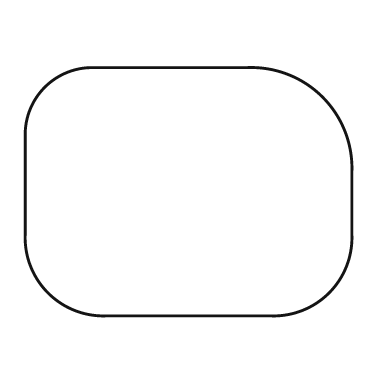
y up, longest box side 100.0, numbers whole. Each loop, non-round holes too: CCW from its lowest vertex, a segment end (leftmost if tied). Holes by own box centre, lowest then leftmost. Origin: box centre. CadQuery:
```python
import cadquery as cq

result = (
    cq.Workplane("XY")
    .moveTo(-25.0, -38.0)
    .lineTo(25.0, -38.0)
    .threePointArc((43.0, -31.0), (50.0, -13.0))
    .lineTo(50.0, 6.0)
    .threePointArc((41.0, 29.0), (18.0, 38.0))
    .lineTo(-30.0, 38.0)
    .threePointArc((-44.0, 32.0), (-50.0, 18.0))
    .lineTo(-50.0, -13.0)
    .threePointArc((-43.0, -31.0), (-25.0, -38.0))
    .close()
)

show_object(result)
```